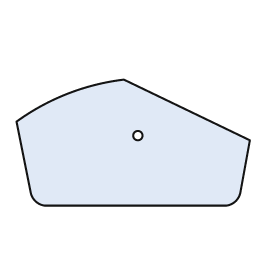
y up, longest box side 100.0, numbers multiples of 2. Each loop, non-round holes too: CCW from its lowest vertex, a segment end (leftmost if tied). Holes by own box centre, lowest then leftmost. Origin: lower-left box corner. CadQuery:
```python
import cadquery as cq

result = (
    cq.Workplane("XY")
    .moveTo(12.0, 0.0)
    .lineTo(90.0, 0.0)
    .threePointArc((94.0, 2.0), (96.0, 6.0))
    .lineTo(100.0, 28.0)
    .lineTo(46.0, 54.0)
    .threePointArc((22.0, 48.0), (0.0, 36.0))
    .lineTo(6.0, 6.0)
    .threePointArc((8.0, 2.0), (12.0, 0.0))
    .close()
    .moveTo(52.0, 30.0)
    .circle(2.0)
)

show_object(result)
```